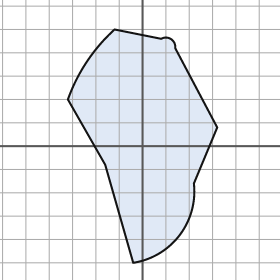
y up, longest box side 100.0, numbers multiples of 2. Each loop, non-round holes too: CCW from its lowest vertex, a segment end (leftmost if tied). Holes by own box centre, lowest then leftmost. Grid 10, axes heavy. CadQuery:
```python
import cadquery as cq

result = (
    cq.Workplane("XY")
    .moveTo(-4.0, -50.0)
    .threePointArc((16.0, -38.0), (22.0, -16.0))
    .lineTo(32.0, 8.0)
    .lineTo(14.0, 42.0)
    .threePointArc((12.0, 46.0), (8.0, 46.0))
    .lineTo(-12.0, 50.0)
    .threePointArc((-24.0, 36.0), (-32.0, 20.0))
    .lineTo(-16.0, -8.0)
    .close()
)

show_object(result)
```